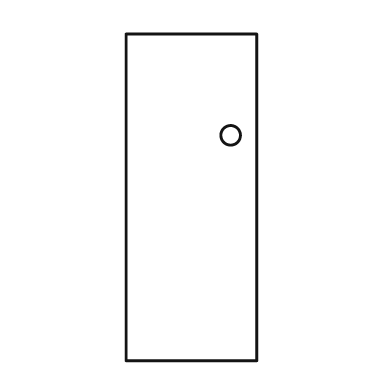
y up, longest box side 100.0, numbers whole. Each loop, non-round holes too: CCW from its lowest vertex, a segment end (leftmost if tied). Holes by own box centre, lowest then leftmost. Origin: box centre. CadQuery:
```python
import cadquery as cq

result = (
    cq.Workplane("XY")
    .moveTo(-20.0, -50.0)
    .lineTo(20.0, -50.0)
    .lineTo(20.0, 50.0)
    .lineTo(-20.0, 50.0)
    .close()
    .moveTo(12.0, 19.0)
    .circle(3.0)
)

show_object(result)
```